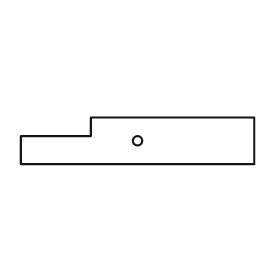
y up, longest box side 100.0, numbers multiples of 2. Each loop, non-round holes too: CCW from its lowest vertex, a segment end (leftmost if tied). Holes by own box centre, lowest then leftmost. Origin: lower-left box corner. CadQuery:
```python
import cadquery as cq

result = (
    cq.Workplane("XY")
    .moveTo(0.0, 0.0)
    .lineTo(100.0, 0.0)
    .lineTo(100.0, 20.0)
    .lineTo(30.0, 20.0)
    .lineTo(30.0, 12.0)
    .lineTo(0.0, 12.0)
    .close()
    .moveTo(50.0, 10.0)
    .circle(2.0)
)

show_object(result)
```